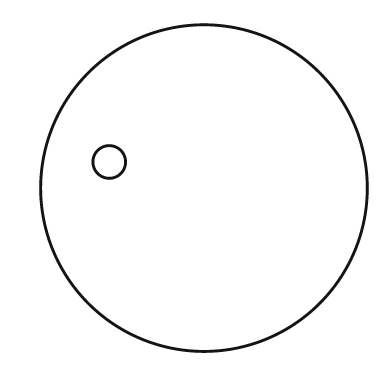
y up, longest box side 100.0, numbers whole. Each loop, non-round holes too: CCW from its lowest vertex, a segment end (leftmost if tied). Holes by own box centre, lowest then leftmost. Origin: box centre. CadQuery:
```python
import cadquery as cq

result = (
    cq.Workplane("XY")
    .moveTo(0.0, 0.0)
    .circle(50.0)
    .moveTo(-29.0, 8.0)
    .circle(5.0)
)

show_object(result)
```